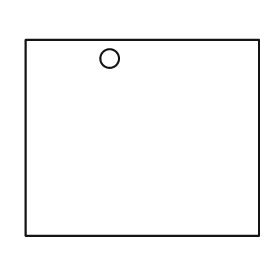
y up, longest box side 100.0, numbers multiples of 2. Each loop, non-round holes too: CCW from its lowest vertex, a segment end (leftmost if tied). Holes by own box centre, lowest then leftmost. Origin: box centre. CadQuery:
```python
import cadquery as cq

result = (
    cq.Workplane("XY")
    .moveTo(-50.0, -42.0)
    .lineTo(50.0, -42.0)
    .lineTo(50.0, 42.0)
    .lineTo(-50.0, 42.0)
    .close()
    .moveTo(-14.0, 34.0)
    .circle(4.0)
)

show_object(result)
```